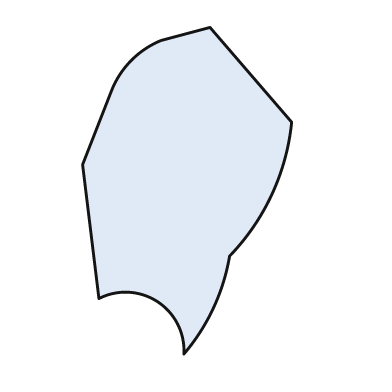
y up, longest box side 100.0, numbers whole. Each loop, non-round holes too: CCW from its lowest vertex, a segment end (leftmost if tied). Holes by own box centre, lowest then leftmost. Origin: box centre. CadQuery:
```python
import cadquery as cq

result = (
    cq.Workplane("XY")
    .moveTo(-1.0, -50.0)
    .threePointArc((8.0, -36.0), (13.0, -20.0))
    .threePointArc((26.0, -1.0), (32.0, 21.0))
    .lineTo(7.0, 50.0)
    .lineTo(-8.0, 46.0)
    .threePointArc((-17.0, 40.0), (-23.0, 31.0))
    .lineTo(-32.0, 8.0)
    .lineTo(-27.0, -33.0)
    .threePointArc((-9.0, -34.0), (-1.0, -50.0))
    .close()
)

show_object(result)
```